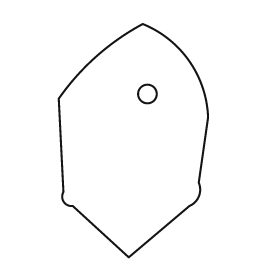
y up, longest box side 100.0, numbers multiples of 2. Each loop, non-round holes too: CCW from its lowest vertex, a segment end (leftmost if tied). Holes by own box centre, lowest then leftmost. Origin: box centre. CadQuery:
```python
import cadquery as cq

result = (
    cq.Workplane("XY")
    .moveTo(-2.0, -50.0)
    .lineTo(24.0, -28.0)
    .threePointArc((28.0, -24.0), (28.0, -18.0))
    .lineTo(32.0, 10.0)
    .threePointArc((24.0, 34.0), (4.0, 50.0))
    .threePointArc((-16.0, 36.0), (-32.0, 18.0))
    .lineTo(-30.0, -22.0)
    .threePointArc((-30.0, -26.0), (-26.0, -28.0))
    .close()
    .moveTo(6.0, 20.0)
    .circle(4.0)
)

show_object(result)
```